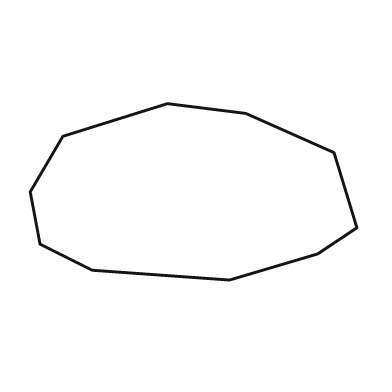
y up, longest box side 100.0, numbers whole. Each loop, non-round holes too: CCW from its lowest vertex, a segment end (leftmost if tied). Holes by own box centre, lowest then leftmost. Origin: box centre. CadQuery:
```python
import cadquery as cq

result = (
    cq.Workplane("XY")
    .moveTo(11.0, -27.0)
    .lineTo(38.0, -19.0)
    .lineTo(50.0, -11.0)
    .lineTo(43.0, 12.0)
    .lineTo(16.0, 24.0)
    .lineTo(-8.0, 27.0)
    .lineTo(-40.0, 17.0)
    .lineTo(-50.0, 0.0)
    .lineTo(-47.0, -16.0)
    .lineTo(-31.0, -24.0)
    .close()
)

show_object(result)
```